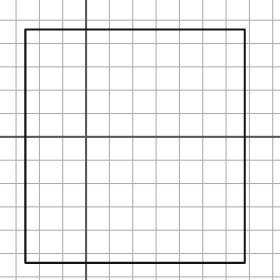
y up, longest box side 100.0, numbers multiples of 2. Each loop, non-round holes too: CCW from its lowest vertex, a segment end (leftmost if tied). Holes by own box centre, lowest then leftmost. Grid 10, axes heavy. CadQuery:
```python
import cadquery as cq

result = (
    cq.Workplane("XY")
    .moveTo(-26.0, -54.0)
    .lineTo(68.0, -54.0)
    .lineTo(68.0, 46.0)
    .lineTo(-26.0, 46.0)
    .close()
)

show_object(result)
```